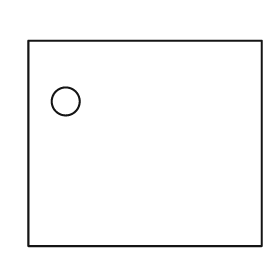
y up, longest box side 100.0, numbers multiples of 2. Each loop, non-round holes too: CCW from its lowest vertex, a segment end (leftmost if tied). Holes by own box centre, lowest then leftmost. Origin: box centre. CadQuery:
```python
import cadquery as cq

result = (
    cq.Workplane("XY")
    .moveTo(-50.0, -44.0)
    .lineTo(50.0, -44.0)
    .lineTo(50.0, 44.0)
    .lineTo(-50.0, 44.0)
    .close()
    .moveTo(-34.0, 18.0)
    .circle(6.0)
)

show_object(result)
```